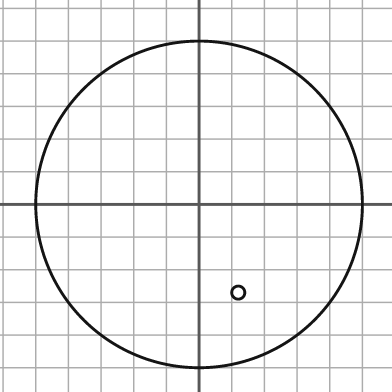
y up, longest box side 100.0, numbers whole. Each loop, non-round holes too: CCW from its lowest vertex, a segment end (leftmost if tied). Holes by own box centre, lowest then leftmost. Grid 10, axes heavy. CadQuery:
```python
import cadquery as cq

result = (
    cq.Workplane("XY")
    .moveTo(0.0, 0.0)
    .circle(50.0)
    .moveTo(12.0, -27.0)
    .circle(2.0)
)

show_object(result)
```